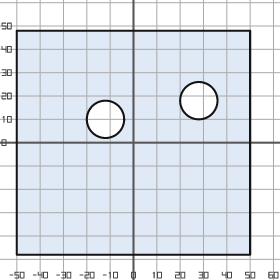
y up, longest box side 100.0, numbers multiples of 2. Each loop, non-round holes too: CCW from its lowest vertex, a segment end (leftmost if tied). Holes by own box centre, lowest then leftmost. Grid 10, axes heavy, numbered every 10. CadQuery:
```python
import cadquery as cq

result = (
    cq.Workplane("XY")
    .moveTo(-50.0, -48.0)
    .lineTo(50.0, -48.0)
    .lineTo(50.0, 48.0)
    .lineTo(-50.0, 48.0)
    .close()
    .moveTo(-12.0, 10.0)
    .circle(8.0)
    .moveTo(28.0, 18.0)
    .circle(8.0)
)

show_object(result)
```